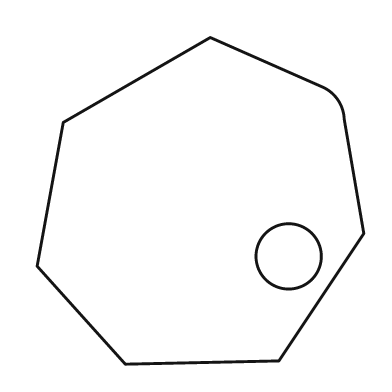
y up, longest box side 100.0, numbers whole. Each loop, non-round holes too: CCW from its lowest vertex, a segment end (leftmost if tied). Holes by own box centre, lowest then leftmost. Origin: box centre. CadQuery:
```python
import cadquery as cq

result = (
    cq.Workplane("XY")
    .moveTo(-23.0, -50.0)
    .lineTo(24.0, -49.0)
    .lineTo(50.0, -10.0)
    .lineTo(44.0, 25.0)
    .threePointArc((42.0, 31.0), (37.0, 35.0))
    .lineTo(3.0, 50.0)
    .lineTo(-42.0, 24.0)
    .lineTo(-50.0, -20.0)
    .close()
    .moveTo(27.0, -17.0)
    .circle(10.0)
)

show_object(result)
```